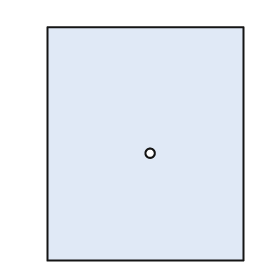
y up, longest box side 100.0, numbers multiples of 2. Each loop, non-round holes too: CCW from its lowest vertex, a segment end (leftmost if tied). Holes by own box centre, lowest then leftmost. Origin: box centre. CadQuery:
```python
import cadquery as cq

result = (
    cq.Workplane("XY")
    .moveTo(-42.0, -50.0)
    .lineTo(42.0, -50.0)
    .lineTo(42.0, 50.0)
    .lineTo(-42.0, 50.0)
    .close()
    .moveTo(2.0, -4.0)
    .circle(2.0)
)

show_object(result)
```